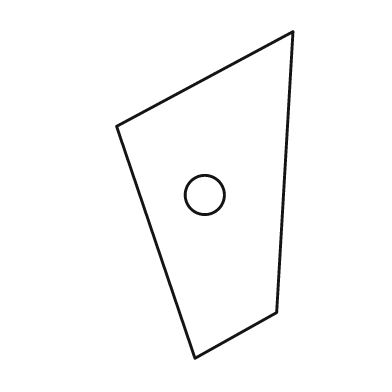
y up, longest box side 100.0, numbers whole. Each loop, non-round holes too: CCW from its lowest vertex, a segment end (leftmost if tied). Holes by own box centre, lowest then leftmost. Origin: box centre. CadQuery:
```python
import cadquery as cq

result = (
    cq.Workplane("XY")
    .moveTo(-3.0, -50.0)
    .lineTo(22.0, -36.0)
    .lineTo(27.0, 50.0)
    .lineTo(-27.0, 21.0)
    .close()
    .moveTo(0.0, 0.0)
    .circle(6.0)
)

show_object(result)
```